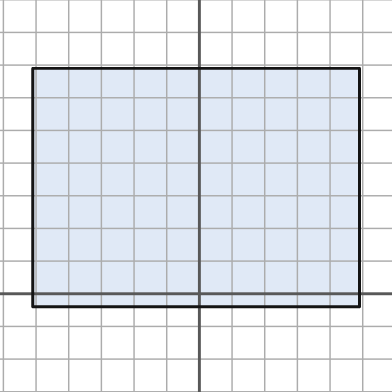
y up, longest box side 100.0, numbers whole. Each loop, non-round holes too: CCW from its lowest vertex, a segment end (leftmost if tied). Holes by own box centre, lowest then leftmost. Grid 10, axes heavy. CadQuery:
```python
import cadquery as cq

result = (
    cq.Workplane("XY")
    .moveTo(-51.0, -4.0)
    .lineTo(49.0, -4.0)
    .lineTo(49.0, 69.0)
    .lineTo(-51.0, 69.0)
    .close()
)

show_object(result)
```